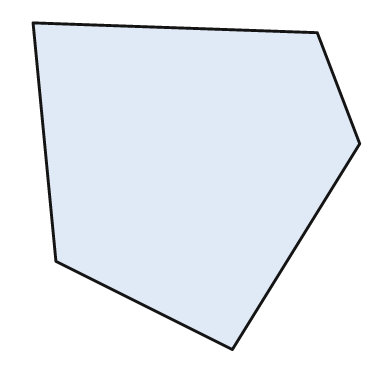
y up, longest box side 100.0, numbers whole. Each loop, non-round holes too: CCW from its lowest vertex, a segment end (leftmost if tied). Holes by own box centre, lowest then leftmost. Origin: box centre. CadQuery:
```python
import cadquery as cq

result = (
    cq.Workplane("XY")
    .moveTo(11.0, -50.0)
    .lineTo(50.0, 13.0)
    .lineTo(37.0, 47.0)
    .lineTo(-50.0, 50.0)
    .lineTo(-43.0, -23.0)
    .close()
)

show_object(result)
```